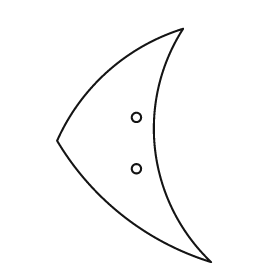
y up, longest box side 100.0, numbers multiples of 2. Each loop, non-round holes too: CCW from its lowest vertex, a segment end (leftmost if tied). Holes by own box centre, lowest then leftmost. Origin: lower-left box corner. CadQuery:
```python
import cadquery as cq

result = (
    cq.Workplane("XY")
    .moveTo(66.0, 0.0)
    .threePointArc((42.0, 48.0), (54.0, 100.0))
    .threePointArc((22.0, 82.0), (0.0, 52.0))
    .threePointArc((28.0, 20.0), (66.0, 0.0))
    .close()
    .moveTo(34.0, 40.0)
    .circle(2.0)
    .moveTo(34.0, 62.0)
    .circle(2.0)
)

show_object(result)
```